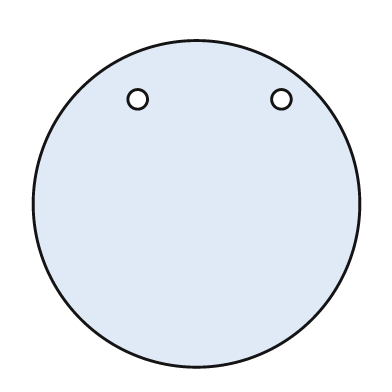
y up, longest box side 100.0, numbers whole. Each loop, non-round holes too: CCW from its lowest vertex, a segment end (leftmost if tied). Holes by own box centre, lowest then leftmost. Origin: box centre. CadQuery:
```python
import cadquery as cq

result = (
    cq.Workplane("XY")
    .moveTo(0.0, 0.0)
    .circle(50.0)
    .moveTo(-18.0, 32.0)
    .circle(3.0)
    .moveTo(26.0, 32.0)
    .circle(3.0)
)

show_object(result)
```